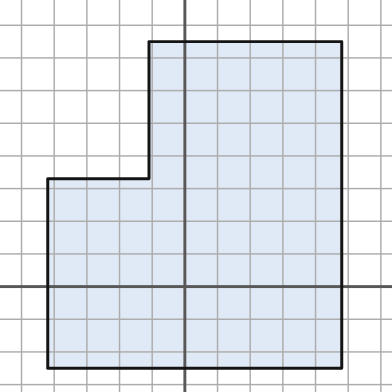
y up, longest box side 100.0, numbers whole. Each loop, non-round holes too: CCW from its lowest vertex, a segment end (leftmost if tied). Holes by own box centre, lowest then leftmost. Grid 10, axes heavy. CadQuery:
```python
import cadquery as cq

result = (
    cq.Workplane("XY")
    .moveTo(-42.0, -25.0)
    .lineTo(48.0, -25.0)
    .lineTo(48.0, 75.0)
    .lineTo(-11.0, 75.0)
    .lineTo(-11.0, 33.0)
    .lineTo(-42.0, 33.0)
    .close()
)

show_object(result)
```